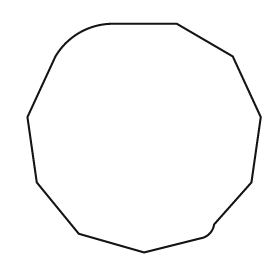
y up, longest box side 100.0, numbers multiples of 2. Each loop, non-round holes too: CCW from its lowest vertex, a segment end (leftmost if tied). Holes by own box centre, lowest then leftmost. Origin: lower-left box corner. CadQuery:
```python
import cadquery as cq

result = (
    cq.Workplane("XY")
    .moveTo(50.0, 0.0)
    .lineTo(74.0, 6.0)
    .threePointArc((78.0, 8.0), (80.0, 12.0))
    .lineTo(96.0, 30.0)
    .lineTo(100.0, 58.0)
    .lineTo(88.0, 84.0)
    .lineTo(64.0, 98.0)
    .lineTo(36.0, 98.0)
    .threePointArc((22.0, 94.0), (12.0, 84.0))
    .lineTo(0.0, 58.0)
    .lineTo(4.0, 30.0)
    .lineTo(22.0, 8.0)
    .close()
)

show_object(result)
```